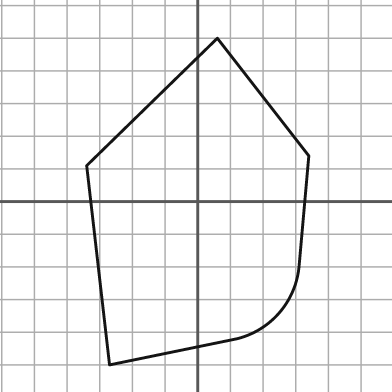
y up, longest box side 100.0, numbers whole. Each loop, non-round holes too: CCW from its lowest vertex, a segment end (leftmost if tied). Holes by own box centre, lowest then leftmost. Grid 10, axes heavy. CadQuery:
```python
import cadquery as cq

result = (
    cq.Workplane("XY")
    .moveTo(-27.0, -50.0)
    .lineTo(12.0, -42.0)
    .threePointArc((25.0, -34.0), (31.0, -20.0))
    .lineTo(34.0, 14.0)
    .lineTo(6.0, 50.0)
    .lineTo(-34.0, 11.0)
    .close()
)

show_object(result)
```